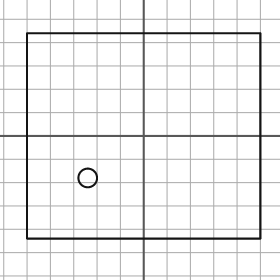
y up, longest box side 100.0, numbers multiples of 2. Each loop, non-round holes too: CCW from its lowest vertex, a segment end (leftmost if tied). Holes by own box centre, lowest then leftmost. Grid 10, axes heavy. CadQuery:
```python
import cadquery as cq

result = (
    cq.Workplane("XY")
    .moveTo(-50.0, -44.0)
    .lineTo(50.0, -44.0)
    .lineTo(50.0, 44.0)
    .lineTo(-50.0, 44.0)
    .close()
    .moveTo(-24.0, -18.0)
    .circle(4.0)
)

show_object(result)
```